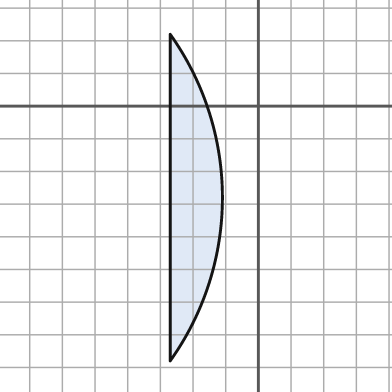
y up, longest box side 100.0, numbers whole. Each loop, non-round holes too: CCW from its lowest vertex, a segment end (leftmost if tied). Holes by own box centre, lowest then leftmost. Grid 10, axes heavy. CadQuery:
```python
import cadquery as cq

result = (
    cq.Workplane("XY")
    .moveTo(-27.0, -78.0)
    .threePointArc((-11.0, -28.0), (-27.0, 22.0))
    .close()
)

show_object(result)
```